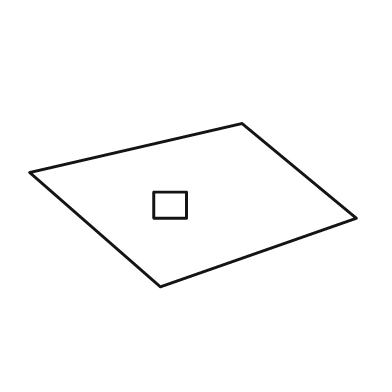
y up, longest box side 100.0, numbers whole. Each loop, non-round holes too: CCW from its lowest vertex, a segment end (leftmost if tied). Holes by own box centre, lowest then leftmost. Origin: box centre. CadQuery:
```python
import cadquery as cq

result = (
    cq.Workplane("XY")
    .moveTo(-10.0, -25.0)
    .lineTo(50.0, -4.0)
    .lineTo(15.0, 25.0)
    .lineTo(-50.0, 10.0)
    .close()
    .moveTo(-12.0, -4.0)
    .lineTo(-2.0, -4.0)
    .lineTo(-2.0, 4.0)
    .lineTo(-12.0, 4.0)
    .close()
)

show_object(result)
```